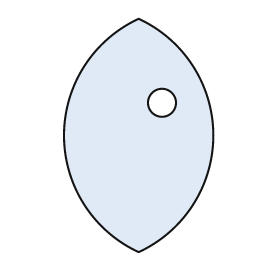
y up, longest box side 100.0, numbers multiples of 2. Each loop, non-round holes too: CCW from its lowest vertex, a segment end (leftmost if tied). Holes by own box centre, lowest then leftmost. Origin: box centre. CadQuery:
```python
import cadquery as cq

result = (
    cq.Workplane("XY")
    .moveTo(0.0, -50.0)
    .threePointArc((32.0, 0.0), (0.0, 50.0))
    .threePointArc((-32.0, 0.0), (0.0, -50.0))
    .close()
    .moveTo(10.0, 14.0)
    .circle(6.0)
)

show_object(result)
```